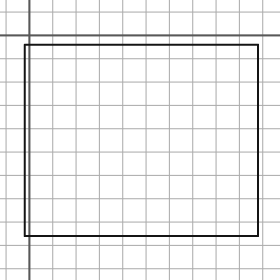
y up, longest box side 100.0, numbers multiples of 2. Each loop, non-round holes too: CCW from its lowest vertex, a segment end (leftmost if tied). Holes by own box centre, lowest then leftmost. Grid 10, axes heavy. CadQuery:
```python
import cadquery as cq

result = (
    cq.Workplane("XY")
    .moveTo(-2.0, -86.0)
    .lineTo(98.0, -86.0)
    .lineTo(98.0, -4.0)
    .lineTo(-2.0, -4.0)
    .close()
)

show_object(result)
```